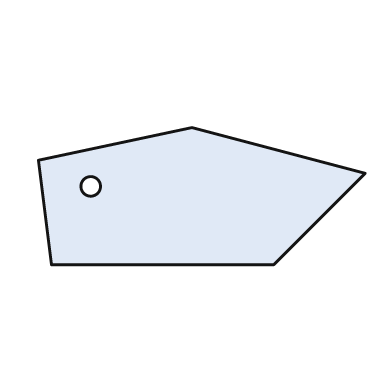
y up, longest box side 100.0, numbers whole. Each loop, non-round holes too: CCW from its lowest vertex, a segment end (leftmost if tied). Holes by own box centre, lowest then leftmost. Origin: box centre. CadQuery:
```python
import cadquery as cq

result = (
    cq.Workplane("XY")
    .moveTo(-46.0, -21.0)
    .lineTo(22.0, -21.0)
    .lineTo(50.0, 7.0)
    .lineTo(-3.0, 21.0)
    .lineTo(-50.0, 11.0)
    .close()
    .moveTo(-34.0, 3.0)
    .circle(3.0)
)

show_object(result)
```